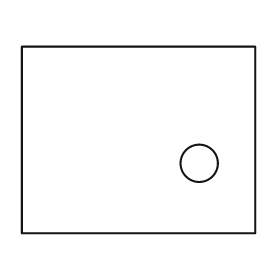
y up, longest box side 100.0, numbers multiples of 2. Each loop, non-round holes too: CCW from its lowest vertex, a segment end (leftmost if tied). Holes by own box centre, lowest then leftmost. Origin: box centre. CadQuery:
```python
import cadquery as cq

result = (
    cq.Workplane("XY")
    .moveTo(-50.0, -40.0)
    .lineTo(50.0, -40.0)
    .lineTo(50.0, 40.0)
    .lineTo(-50.0, 40.0)
    .close()
    .moveTo(26.0, -10.0)
    .circle(8.0)
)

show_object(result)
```